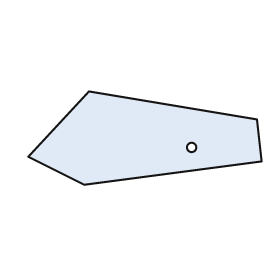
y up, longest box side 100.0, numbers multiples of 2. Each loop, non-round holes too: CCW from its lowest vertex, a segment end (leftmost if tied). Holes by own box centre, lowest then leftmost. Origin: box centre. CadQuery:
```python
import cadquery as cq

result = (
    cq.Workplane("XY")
    .moveTo(-26.0, -20.0)
    .lineTo(50.0, -10.0)
    .lineTo(48.0, 8.0)
    .lineTo(-24.0, 20.0)
    .lineTo(-50.0, -8.0)
    .close()
    .moveTo(20.0, -4.0)
    .circle(2.0)
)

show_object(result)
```